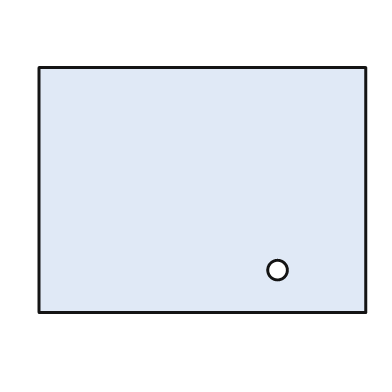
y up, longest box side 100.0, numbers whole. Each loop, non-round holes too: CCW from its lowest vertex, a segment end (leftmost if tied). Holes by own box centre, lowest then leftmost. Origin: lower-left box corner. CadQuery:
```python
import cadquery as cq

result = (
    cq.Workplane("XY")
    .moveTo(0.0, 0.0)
    .lineTo(100.0, 0.0)
    .lineTo(100.0, 75.0)
    .lineTo(0.0, 75.0)
    .close()
    .moveTo(73.0, 13.0)
    .circle(3.0)
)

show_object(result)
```